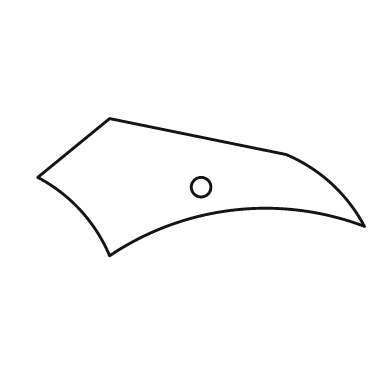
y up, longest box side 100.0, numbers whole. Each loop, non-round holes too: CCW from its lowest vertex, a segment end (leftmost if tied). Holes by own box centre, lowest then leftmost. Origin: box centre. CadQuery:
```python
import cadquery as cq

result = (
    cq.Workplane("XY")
    .moveTo(-28.0, -21.0)
    .threePointArc((10.0, -7.0), (50.0, -12.0))
    .threePointArc((40.0, 1.0), (26.0, 10.0))
    .lineTo(-28.0, 21.0)
    .lineTo(-50.0, 3.0)
    .threePointArc((-37.0, -7.0), (-28.0, -21.0))
    .close()
    .moveTo(0.0, 0.0)
    .circle(3.0)
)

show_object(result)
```